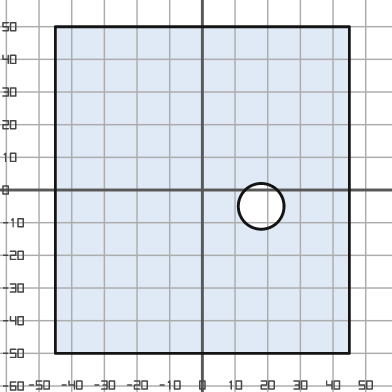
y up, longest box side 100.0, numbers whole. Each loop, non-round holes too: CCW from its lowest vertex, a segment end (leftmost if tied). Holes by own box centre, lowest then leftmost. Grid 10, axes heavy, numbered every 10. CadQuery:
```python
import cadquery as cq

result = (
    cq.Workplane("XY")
    .moveTo(-45.0, -50.0)
    .lineTo(45.0, -50.0)
    .lineTo(45.0, 50.0)
    .lineTo(-45.0, 50.0)
    .close()
    .moveTo(18.0, -5.0)
    .circle(7.0)
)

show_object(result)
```